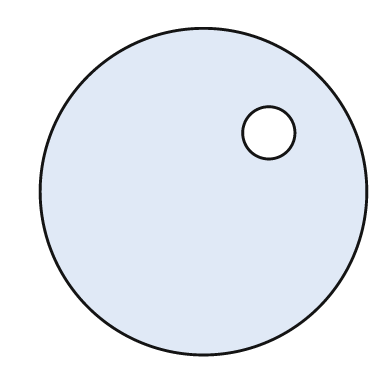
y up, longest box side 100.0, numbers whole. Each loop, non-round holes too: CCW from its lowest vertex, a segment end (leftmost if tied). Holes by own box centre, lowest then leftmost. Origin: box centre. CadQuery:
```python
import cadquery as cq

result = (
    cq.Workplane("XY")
    .moveTo(0.0, 0.0)
    .circle(50.0)
    .moveTo(20.0, 18.0)
    .circle(8.0)
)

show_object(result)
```